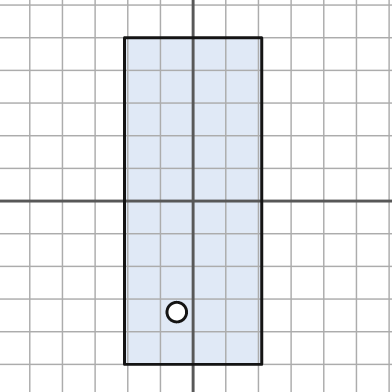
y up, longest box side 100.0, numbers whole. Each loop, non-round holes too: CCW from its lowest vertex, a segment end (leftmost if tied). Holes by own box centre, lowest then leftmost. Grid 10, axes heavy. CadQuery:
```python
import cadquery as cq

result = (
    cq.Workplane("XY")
    .moveTo(-21.0, -50.0)
    .lineTo(21.0, -50.0)
    .lineTo(21.0, 50.0)
    .lineTo(-21.0, 50.0)
    .close()
    .moveTo(-5.0, -34.0)
    .circle(3.0)
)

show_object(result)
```